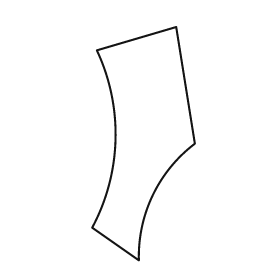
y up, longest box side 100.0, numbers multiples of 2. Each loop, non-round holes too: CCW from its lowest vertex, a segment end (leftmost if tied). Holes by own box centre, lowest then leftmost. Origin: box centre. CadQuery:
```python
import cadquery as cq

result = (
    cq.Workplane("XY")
    .moveTo(-2.0, -50.0)
    .threePointArc((4.0, -22.0), (22.0, 0.0))
    .lineTo(14.0, 50.0)
    .lineTo(-20.0, 40.0)
    .threePointArc((-12.0, 2.0), (-22.0, -36.0))
    .close()
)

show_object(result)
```